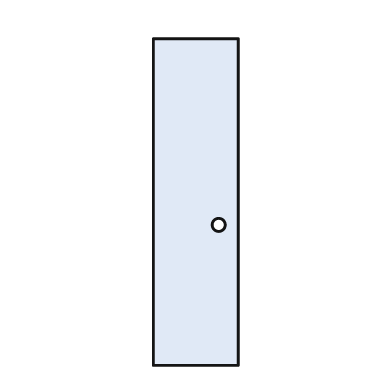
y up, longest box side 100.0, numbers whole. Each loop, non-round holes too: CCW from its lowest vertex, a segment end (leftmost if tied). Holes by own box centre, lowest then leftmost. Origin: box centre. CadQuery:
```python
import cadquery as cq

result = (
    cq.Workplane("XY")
    .moveTo(-13.0, -50.0)
    .lineTo(13.0, -50.0)
    .lineTo(13.0, 50.0)
    .lineTo(-13.0, 50.0)
    .close()
    .moveTo(7.0, -7.0)
    .circle(2.0)
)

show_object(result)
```